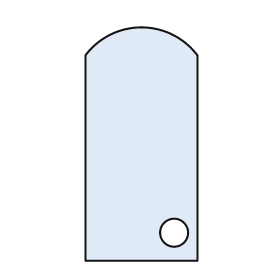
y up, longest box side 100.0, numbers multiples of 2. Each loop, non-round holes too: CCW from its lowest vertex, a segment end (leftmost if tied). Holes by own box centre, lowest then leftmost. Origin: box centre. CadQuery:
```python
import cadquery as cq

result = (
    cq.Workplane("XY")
    .moveTo(-24.0, -50.0)
    .lineTo(24.0, -50.0)
    .lineTo(24.0, 38.0)
    .threePointArc((0.0, 50.0), (-24.0, 38.0))
    .close()
    .moveTo(14.0, -38.0)
    .circle(6.0)
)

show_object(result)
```